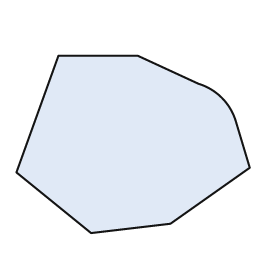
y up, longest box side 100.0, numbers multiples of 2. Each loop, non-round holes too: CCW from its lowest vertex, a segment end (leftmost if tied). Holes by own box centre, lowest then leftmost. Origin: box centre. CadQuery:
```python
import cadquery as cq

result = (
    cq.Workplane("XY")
    .moveTo(-18.0, -38.0)
    .lineTo(16.0, -34.0)
    .lineTo(50.0, -10.0)
    .lineTo(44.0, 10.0)
    .threePointArc((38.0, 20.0), (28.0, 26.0))
    .lineTo(2.0, 38.0)
    .lineTo(-32.0, 38.0)
    .lineTo(-50.0, -12.0)
    .close()
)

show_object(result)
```